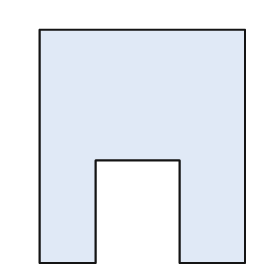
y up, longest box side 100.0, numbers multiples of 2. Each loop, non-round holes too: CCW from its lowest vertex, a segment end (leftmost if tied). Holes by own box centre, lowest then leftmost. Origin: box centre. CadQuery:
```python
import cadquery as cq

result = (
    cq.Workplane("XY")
    .moveTo(-44.0, -50.0)
    .lineTo(-20.0, -50.0)
    .lineTo(-20.0, -6.0)
    .lineTo(16.0, -6.0)
    .lineTo(16.0, -50.0)
    .lineTo(44.0, -50.0)
    .lineTo(44.0, 50.0)
    .lineTo(-44.0, 50.0)
    .close()
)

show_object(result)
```